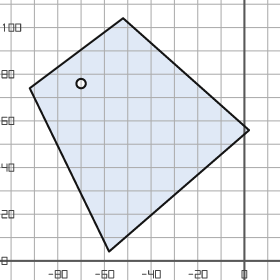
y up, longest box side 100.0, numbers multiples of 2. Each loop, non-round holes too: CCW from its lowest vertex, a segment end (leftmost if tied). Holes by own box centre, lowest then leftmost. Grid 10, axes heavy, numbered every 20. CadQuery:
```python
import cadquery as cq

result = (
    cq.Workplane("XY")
    .moveTo(-58.0, 4.0)
    .lineTo(2.0, 56.0)
    .lineTo(-52.0, 104.0)
    .lineTo(-92.0, 74.0)
    .close()
    .moveTo(-70.0, 76.0)
    .circle(2.0)
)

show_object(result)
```